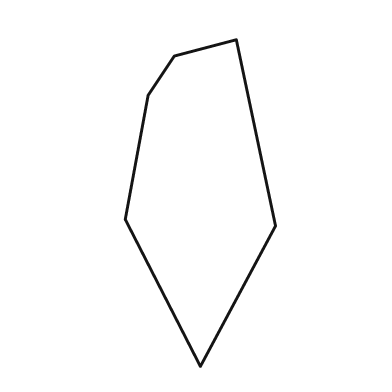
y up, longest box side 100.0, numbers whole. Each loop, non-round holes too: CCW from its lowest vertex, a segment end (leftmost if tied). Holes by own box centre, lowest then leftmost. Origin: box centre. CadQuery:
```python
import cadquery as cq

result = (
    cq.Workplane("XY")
    .moveTo(0.0, -50.0)
    .lineTo(23.0, -7.0)
    .lineTo(11.0, 50.0)
    .lineTo(-8.0, 45.0)
    .lineTo(-16.0, 33.0)
    .lineTo(-23.0, -5.0)
    .close()
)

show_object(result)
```